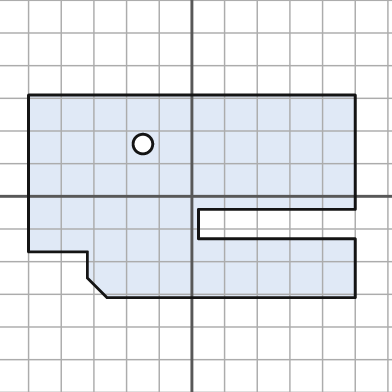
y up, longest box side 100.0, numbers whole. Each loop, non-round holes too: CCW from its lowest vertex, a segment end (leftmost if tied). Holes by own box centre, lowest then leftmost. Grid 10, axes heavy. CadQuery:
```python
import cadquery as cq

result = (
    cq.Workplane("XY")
    .moveTo(-26.0, -31.0)
    .lineTo(50.0, -31.0)
    .lineTo(50.0, -13.0)
    .lineTo(2.0, -13.0)
    .lineTo(2.0, -4.0)
    .lineTo(50.0, -4.0)
    .lineTo(50.0, 31.0)
    .lineTo(-50.0, 31.0)
    .lineTo(-50.0, -17.0)
    .lineTo(-32.0, -17.0)
    .lineTo(-32.0, -25.0)
    .close()
    .moveTo(-15.0, 16.0)
    .circle(3.0)
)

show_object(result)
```